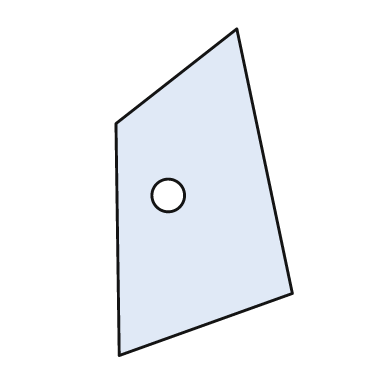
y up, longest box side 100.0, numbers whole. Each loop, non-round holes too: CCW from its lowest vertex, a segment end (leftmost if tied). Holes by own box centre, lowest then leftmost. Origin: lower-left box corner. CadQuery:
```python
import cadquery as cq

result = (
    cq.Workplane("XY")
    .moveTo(1.0, 0.0)
    .lineTo(54.0, 19.0)
    .lineTo(37.0, 100.0)
    .lineTo(0.0, 71.0)
    .close()
    .moveTo(16.0, 49.0)
    .circle(5.0)
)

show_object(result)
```